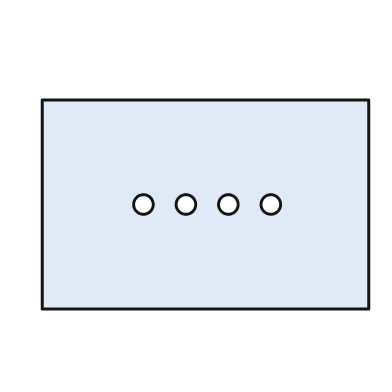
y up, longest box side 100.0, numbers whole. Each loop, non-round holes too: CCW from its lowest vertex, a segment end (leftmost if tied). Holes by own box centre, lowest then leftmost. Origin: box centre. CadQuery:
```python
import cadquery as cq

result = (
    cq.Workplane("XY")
    .moveTo(-50.0, -32.0)
    .lineTo(50.0, -32.0)
    .lineTo(50.0, 32.0)
    .lineTo(-50.0, 32.0)
    .close()
    .moveTo(-19.0, 0.0)
    .circle(3.0)
    .moveTo(-6.0, 0.0)
    .circle(3.0)
    .moveTo(7.0, 0.0)
    .circle(3.0)
    .moveTo(20.0, 0.0)
    .circle(3.0)
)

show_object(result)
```